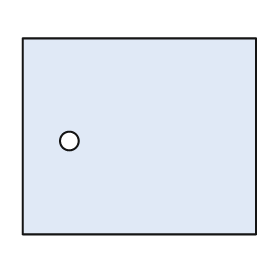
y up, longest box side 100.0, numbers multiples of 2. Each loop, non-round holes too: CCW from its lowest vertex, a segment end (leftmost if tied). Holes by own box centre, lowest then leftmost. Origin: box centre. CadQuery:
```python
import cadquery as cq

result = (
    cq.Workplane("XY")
    .moveTo(-50.0, -42.0)
    .lineTo(50.0, -42.0)
    .lineTo(50.0, 42.0)
    .lineTo(-50.0, 42.0)
    .close()
    .moveTo(-30.0, -2.0)
    .circle(4.0)
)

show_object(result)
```